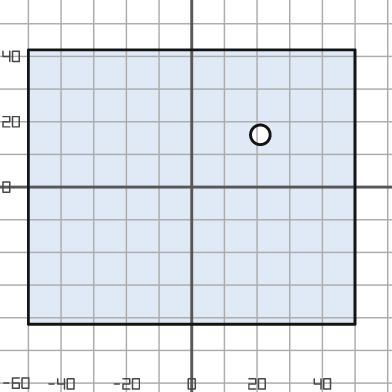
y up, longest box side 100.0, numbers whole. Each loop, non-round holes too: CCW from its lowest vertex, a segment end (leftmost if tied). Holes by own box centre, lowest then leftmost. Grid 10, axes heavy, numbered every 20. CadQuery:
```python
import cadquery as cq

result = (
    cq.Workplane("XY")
    .moveTo(-50.0, -42.0)
    .lineTo(50.0, -42.0)
    .lineTo(50.0, 42.0)
    .lineTo(-50.0, 42.0)
    .close()
    .moveTo(21.0, 16.0)
    .circle(3.0)
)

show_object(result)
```